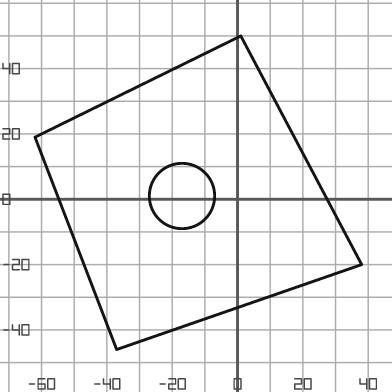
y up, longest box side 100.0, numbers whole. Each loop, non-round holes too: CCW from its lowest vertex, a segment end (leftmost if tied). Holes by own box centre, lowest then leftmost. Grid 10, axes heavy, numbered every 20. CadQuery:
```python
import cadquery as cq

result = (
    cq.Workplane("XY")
    .moveTo(-37.0, -46.0)
    .lineTo(38.0, -20.0)
    .lineTo(1.0, 50.0)
    .lineTo(-62.0, 19.0)
    .close()
    .moveTo(-17.0, 1.0)
    .circle(10.0)
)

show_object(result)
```